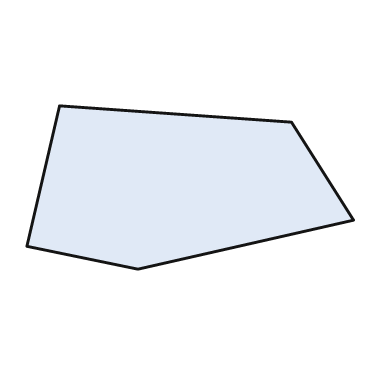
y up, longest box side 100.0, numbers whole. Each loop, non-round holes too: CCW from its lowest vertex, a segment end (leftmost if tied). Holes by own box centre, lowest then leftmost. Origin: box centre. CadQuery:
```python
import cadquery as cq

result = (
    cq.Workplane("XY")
    .moveTo(-16.0, -25.0)
    .lineTo(50.0, -10.0)
    .lineTo(31.0, 20.0)
    .lineTo(-40.0, 25.0)
    .lineTo(-50.0, -18.0)
    .close()
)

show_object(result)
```